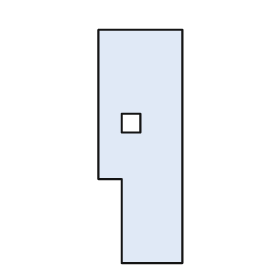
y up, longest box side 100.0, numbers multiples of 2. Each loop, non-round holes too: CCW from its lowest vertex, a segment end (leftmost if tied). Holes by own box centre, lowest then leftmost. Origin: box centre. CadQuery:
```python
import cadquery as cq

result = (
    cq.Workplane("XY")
    .moveTo(-8.0, -50.0)
    .lineTo(18.0, -50.0)
    .lineTo(18.0, 50.0)
    .lineTo(-18.0, 50.0)
    .lineTo(-18.0, -14.0)
    .lineTo(-8.0, -14.0)
    .close()
    .moveTo(-8.0, 6.0)
    .lineTo(0.0, 6.0)
    .lineTo(0.0, 14.0)
    .lineTo(-8.0, 14.0)
    .close()
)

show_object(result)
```